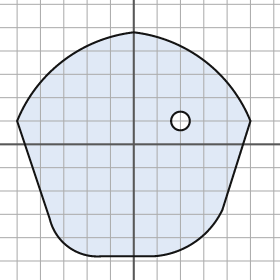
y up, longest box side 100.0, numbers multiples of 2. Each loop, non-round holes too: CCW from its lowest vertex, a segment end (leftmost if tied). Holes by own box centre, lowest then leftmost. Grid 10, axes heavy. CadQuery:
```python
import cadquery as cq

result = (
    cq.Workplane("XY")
    .moveTo(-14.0, -48.0)
    .lineTo(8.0, -48.0)
    .threePointArc((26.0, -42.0), (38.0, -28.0))
    .lineTo(50.0, 10.0)
    .threePointArc((30.0, 36.0), (0.0, 48.0))
    .threePointArc((-30.0, 36.0), (-50.0, 10.0))
    .lineTo(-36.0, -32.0)
    .threePointArc((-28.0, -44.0), (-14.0, -48.0))
    .close()
    .moveTo(20.0, 10.0)
    .circle(4.0)
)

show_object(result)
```